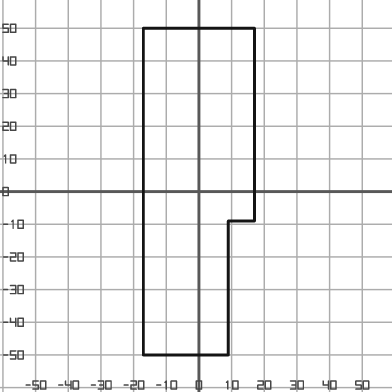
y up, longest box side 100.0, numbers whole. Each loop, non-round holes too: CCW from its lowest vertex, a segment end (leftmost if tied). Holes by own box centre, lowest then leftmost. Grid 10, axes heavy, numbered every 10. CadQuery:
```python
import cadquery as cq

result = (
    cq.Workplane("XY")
    .moveTo(-17.0, -50.0)
    .lineTo(9.0, -50.0)
    .lineTo(9.0, -9.0)
    .lineTo(17.0, -9.0)
    .lineTo(17.0, 50.0)
    .lineTo(-17.0, 50.0)
    .close()
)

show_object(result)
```